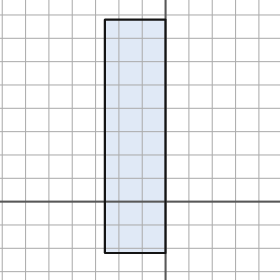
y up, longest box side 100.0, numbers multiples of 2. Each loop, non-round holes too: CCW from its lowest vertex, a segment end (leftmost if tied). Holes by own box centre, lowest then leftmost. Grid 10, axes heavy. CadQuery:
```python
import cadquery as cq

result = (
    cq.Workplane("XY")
    .moveTo(-26.0, -22.0)
    .lineTo(0.0, -22.0)
    .lineTo(0.0, 78.0)
    .lineTo(-26.0, 78.0)
    .close()
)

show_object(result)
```